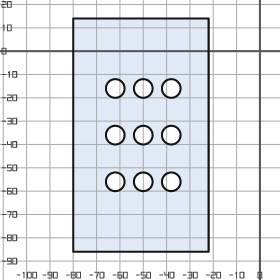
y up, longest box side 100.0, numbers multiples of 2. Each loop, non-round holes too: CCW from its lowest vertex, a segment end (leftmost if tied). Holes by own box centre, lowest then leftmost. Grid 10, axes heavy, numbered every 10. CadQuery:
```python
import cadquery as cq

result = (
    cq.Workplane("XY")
    .moveTo(-80.0, -86.0)
    .lineTo(-22.0, -86.0)
    .lineTo(-22.0, 14.0)
    .lineTo(-80.0, 14.0)
    .close()
    .moveTo(-62.0, -56.0)
    .circle(4.0)
    .moveTo(-50.0, -56.0)
    .circle(4.0)
    .moveTo(-38.0, -56.0)
    .circle(4.0)
    .moveTo(-62.0, -36.0)
    .circle(4.0)
    .moveTo(-50.0, -36.0)
    .circle(4.0)
    .moveTo(-38.0, -36.0)
    .circle(4.0)
    .moveTo(-62.0, -16.0)
    .circle(4.0)
    .moveTo(-50.0, -16.0)
    .circle(4.0)
    .moveTo(-38.0, -16.0)
    .circle(4.0)
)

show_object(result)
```